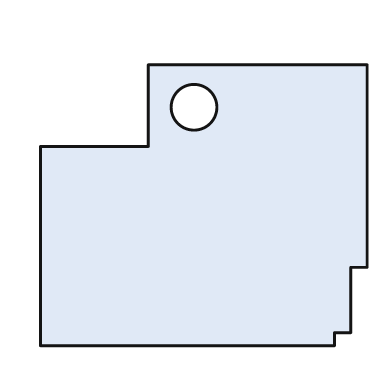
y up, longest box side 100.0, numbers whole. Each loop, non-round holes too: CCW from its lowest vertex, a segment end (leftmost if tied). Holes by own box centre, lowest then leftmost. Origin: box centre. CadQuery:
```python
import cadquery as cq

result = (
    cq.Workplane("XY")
    .moveTo(-50.0, -43.0)
    .lineTo(40.0, -43.0)
    .lineTo(40.0, -39.0)
    .lineTo(45.0, -39.0)
    .lineTo(45.0, -19.0)
    .lineTo(50.0, -19.0)
    .lineTo(50.0, 43.0)
    .lineTo(-17.0, 43.0)
    .lineTo(-17.0, 18.0)
    .lineTo(-50.0, 18.0)
    .close()
    .moveTo(-3.0, 30.0)
    .circle(7.0)
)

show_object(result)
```